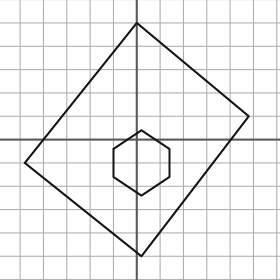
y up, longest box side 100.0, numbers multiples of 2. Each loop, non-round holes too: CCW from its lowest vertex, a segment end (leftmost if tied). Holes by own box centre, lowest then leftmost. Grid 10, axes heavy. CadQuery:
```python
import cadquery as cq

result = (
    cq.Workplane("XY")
    .moveTo(2.0, -50.0)
    .lineTo(48.0, 10.0)
    .lineTo(0.0, 50.0)
    .lineTo(-48.0, -10.0)
    .close()
    .moveTo(2.0, -24.0)
    .lineTo(14.0, -16.0)
    .lineTo(14.0, -4.0)
    .lineTo(2.0, 4.0)
    .lineTo(-10.0, -4.0)
    .lineTo(-10.0, -16.0)
    .close()
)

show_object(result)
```